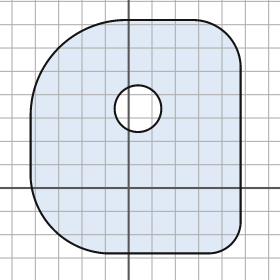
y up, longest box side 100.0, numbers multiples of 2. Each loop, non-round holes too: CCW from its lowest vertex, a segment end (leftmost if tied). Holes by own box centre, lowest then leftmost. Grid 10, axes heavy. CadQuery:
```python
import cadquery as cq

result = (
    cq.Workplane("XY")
    .moveTo(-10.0, -28.0)
    .lineTo(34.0, -28.0)
    .threePointArc((44.0, -24.0), (48.0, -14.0))
    .lineTo(48.0, 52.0)
    .threePointArc((42.0, 66.0), (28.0, 72.0))
    .lineTo(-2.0, 72.0)
    .threePointArc((-30.0, 60.0), (-42.0, 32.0))
    .lineTo(-42.0, 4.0)
    .threePointArc((-32.0, -18.0), (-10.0, -28.0))
    .close()
    .moveTo(4.0, 34.0)
    .circle(10.0)
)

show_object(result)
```